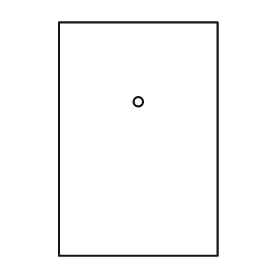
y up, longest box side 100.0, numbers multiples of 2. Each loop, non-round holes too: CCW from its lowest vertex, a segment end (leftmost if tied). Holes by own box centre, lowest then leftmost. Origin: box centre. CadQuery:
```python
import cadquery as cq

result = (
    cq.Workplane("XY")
    .moveTo(-34.0, -50.0)
    .lineTo(34.0, -50.0)
    .lineTo(34.0, 50.0)
    .lineTo(-34.0, 50.0)
    .close()
    .moveTo(0.0, 16.0)
    .circle(2.0)
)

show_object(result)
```